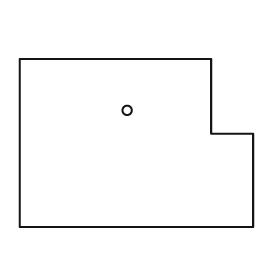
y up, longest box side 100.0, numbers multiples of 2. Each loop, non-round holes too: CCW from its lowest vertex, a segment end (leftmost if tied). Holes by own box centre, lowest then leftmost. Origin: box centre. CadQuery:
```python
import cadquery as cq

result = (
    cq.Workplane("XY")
    .moveTo(-50.0, -36.0)
    .lineTo(50.0, -36.0)
    .lineTo(50.0, 4.0)
    .lineTo(32.0, 4.0)
    .lineTo(32.0, 36.0)
    .lineTo(-50.0, 36.0)
    .close()
    .moveTo(-4.0, 14.0)
    .circle(2.0)
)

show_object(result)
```